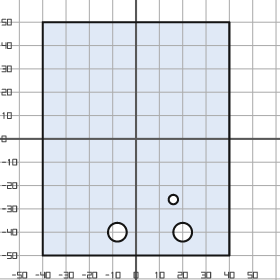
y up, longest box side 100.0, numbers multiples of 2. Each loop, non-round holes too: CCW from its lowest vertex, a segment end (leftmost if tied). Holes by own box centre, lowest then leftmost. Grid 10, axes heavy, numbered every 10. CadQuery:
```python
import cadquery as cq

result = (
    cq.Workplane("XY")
    .moveTo(-40.0, -50.0)
    .lineTo(40.0, -50.0)
    .lineTo(40.0, 50.0)
    .lineTo(-40.0, 50.0)
    .close()
    .moveTo(-8.0, -40.0)
    .circle(4.0)
    .moveTo(20.0, -40.0)
    .circle(4.0)
    .moveTo(16.0, -26.0)
    .circle(2.0)
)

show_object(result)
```